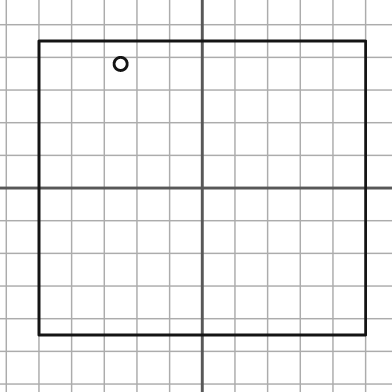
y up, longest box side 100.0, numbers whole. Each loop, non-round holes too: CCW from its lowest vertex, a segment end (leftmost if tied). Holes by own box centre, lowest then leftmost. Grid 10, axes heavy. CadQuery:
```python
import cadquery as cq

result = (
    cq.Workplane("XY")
    .moveTo(-50.0, -45.0)
    .lineTo(50.0, -45.0)
    .lineTo(50.0, 45.0)
    .lineTo(-50.0, 45.0)
    .close()
    .moveTo(-25.0, 38.0)
    .circle(2.0)
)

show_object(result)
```